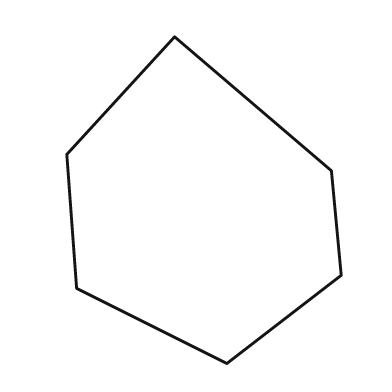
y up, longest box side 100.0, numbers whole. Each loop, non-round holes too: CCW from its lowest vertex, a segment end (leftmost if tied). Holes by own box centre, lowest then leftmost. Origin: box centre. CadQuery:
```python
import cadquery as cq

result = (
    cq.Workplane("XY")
    .moveTo(7.0, -50.0)
    .lineTo(42.0, -23.0)
    .lineTo(39.0, 9.0)
    .lineTo(-9.0, 50.0)
    .lineTo(-42.0, 14.0)
    .lineTo(-39.0, -27.0)
    .close()
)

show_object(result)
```